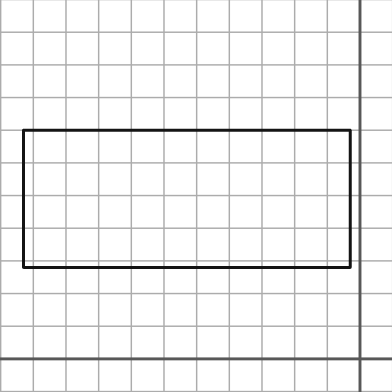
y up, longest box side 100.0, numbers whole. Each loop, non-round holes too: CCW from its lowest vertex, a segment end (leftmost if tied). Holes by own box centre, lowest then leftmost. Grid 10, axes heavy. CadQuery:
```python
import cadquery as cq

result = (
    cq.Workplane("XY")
    .moveTo(-103.0, 28.0)
    .lineTo(-3.0, 28.0)
    .lineTo(-3.0, 70.0)
    .lineTo(-103.0, 70.0)
    .close()
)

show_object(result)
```